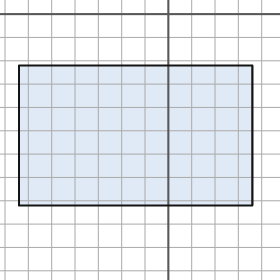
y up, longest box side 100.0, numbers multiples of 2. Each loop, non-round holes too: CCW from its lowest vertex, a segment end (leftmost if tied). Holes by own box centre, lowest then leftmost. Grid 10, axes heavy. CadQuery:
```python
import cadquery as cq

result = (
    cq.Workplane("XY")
    .moveTo(-64.0, -82.0)
    .lineTo(36.0, -82.0)
    .lineTo(36.0, -22.0)
    .lineTo(-64.0, -22.0)
    .close()
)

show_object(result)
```